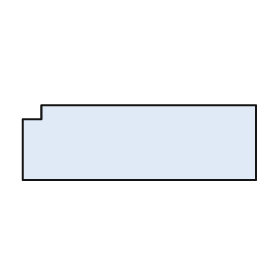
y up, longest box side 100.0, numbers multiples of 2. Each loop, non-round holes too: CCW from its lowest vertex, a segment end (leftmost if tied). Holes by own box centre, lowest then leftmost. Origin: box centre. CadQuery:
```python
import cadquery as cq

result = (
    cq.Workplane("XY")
    .moveTo(-50.0, -16.0)
    .lineTo(50.0, -16.0)
    .lineTo(50.0, 16.0)
    .lineTo(-42.0, 16.0)
    .lineTo(-42.0, 10.0)
    .lineTo(-50.0, 10.0)
    .close()
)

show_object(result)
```